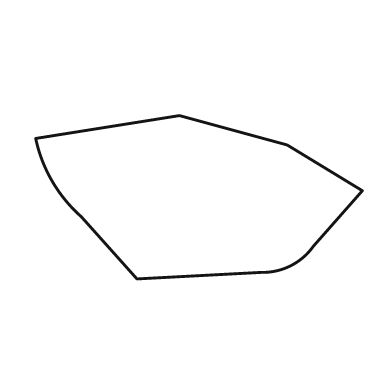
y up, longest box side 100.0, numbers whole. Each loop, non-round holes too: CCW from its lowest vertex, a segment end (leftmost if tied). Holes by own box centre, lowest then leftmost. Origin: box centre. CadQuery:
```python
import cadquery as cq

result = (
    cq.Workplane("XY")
    .moveTo(-19.0, -25.0)
    .lineTo(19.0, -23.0)
    .threePointArc((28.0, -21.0), (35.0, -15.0))
    .lineTo(50.0, 2.0)
    .lineTo(27.0, 16.0)
    .lineTo(-6.0, 25.0)
    .lineTo(-50.0, 18.0)
    .threePointArc((-45.0, 5.0), (-36.0, -6.0))
    .close()
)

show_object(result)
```